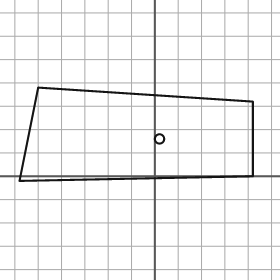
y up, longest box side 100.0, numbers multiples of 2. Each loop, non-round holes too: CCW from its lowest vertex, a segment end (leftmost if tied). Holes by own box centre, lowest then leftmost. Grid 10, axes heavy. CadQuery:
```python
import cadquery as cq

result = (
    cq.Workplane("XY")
    .moveTo(-58.0, -2.0)
    .lineTo(42.0, 0.0)
    .lineTo(42.0, 32.0)
    .lineTo(-50.0, 38.0)
    .close()
    .moveTo(2.0, 16.0)
    .circle(2.0)
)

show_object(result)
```